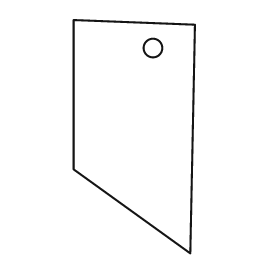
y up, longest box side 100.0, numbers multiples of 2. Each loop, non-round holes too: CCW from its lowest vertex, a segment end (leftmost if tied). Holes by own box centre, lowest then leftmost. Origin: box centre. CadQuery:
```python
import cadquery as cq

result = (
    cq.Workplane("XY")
    .moveTo(24.0, -50.0)
    .lineTo(26.0, 48.0)
    .lineTo(-26.0, 50.0)
    .lineTo(-26.0, -14.0)
    .close()
    .moveTo(8.0, 38.0)
    .circle(4.0)
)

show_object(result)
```